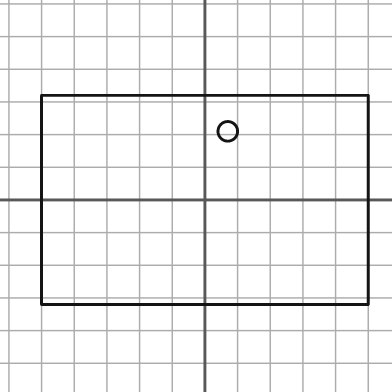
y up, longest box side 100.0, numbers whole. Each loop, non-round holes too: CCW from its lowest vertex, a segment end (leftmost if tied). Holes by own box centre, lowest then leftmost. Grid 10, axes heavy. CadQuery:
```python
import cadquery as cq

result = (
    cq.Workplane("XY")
    .moveTo(-50.0, -32.0)
    .lineTo(50.0, -32.0)
    .lineTo(50.0, 32.0)
    .lineTo(-50.0, 32.0)
    .close()
    .moveTo(7.0, 21.0)
    .circle(3.0)
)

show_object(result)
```